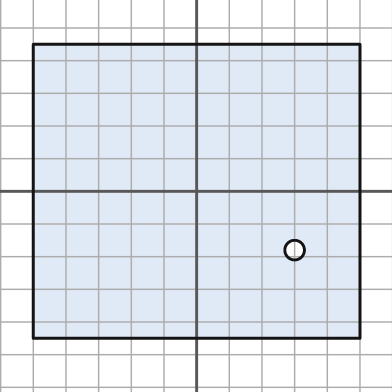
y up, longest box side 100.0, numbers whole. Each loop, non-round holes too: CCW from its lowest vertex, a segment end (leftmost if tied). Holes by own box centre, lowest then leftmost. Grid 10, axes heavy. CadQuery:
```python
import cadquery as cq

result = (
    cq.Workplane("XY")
    .moveTo(-50.0, -45.0)
    .lineTo(50.0, -45.0)
    .lineTo(50.0, 45.0)
    .lineTo(-50.0, 45.0)
    .close()
    .moveTo(30.0, -18.0)
    .circle(3.0)
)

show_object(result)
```